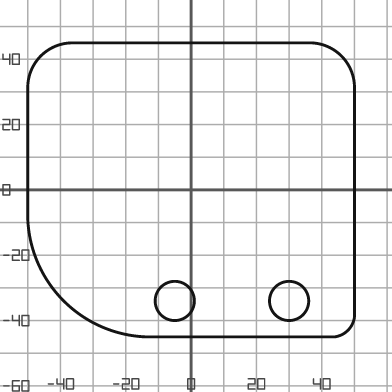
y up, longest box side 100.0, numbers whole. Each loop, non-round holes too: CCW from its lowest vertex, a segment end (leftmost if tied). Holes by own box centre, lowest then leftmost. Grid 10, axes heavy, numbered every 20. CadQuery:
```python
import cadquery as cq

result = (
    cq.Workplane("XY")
    .moveTo(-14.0, -45.0)
    .lineTo(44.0, -45.0)
    .threePointArc((48.0, -43.0), (50.0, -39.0))
    .lineTo(50.0, 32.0)
    .threePointArc((46.0, 41.0), (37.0, 45.0))
    .lineTo(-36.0, 45.0)
    .threePointArc((-46.0, 41.0), (-50.0, 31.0))
    .lineTo(-50.0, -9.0)
    .threePointArc((-39.0, -34.0), (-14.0, -45.0))
    .close()
    .moveTo(-5.0, -34.0)
    .circle(6.0)
    .moveTo(30.0, -34.0)
    .circle(6.0)
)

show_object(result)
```